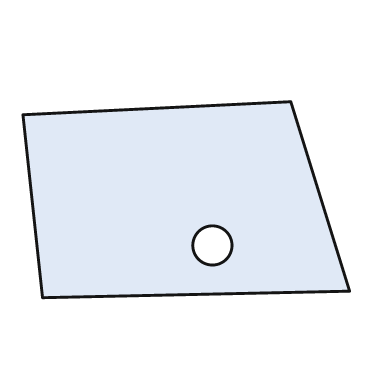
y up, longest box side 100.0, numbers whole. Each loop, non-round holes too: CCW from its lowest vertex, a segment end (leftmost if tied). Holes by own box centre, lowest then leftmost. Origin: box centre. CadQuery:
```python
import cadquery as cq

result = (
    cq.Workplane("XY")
    .moveTo(-44.0, -30.0)
    .lineTo(50.0, -28.0)
    .lineTo(32.0, 30.0)
    .lineTo(-50.0, 26.0)
    .close()
    .moveTo(8.0, -14.0)
    .circle(6.0)
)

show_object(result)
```